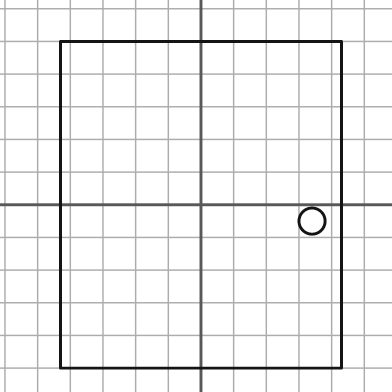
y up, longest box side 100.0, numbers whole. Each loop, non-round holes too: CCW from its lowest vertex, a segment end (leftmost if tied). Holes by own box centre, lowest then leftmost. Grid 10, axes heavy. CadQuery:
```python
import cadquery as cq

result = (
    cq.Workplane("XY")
    .moveTo(-43.0, -50.0)
    .lineTo(43.0, -50.0)
    .lineTo(43.0, 50.0)
    .lineTo(-43.0, 50.0)
    .close()
    .moveTo(34.0, -5.0)
    .circle(4.0)
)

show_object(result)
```